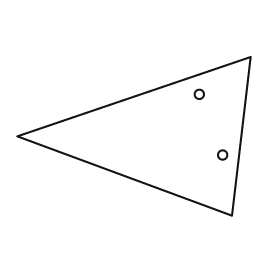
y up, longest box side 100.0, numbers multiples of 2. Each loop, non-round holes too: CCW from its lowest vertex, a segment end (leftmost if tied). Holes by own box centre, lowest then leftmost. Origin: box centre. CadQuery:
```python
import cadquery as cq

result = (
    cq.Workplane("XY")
    .moveTo(42.0, -34.0)
    .lineTo(50.0, 34.0)
    .lineTo(-50.0, 0.0)
    .close()
    .moveTo(38.0, -8.0)
    .circle(2.0)
    .moveTo(28.0, 18.0)
    .circle(2.0)
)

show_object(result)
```